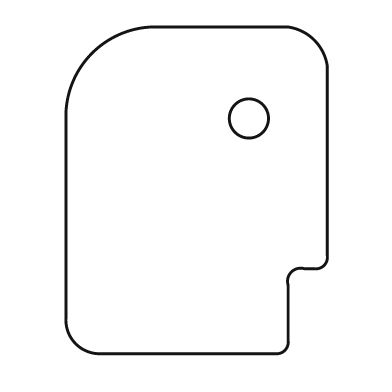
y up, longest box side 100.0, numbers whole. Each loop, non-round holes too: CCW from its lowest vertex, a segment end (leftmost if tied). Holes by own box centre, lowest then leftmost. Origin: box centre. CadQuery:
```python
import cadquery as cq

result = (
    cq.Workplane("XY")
    .moveTo(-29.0, -50.0)
    .lineTo(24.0, -50.0)
    .threePointArc((27.0, -49.0), (28.0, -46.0))
    .lineTo(28.0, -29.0)
    .threePointArc((29.0, -25.0), (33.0, -24.0))
    .lineTo(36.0, -24.0)
    .threePointArc((39.0, -23.0), (40.0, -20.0))
    .lineTo(40.0, 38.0)
    .threePointArc((36.0, 46.0), (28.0, 50.0))
    .lineTo(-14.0, 50.0)
    .threePointArc((-32.0, 42.0), (-40.0, 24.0))
    .lineTo(-40.0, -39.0)
    .threePointArc((-37.0, -47.0), (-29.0, -50.0))
    .close()
    .moveTo(16.0, 22.0)
    .circle(6.0)
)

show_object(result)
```